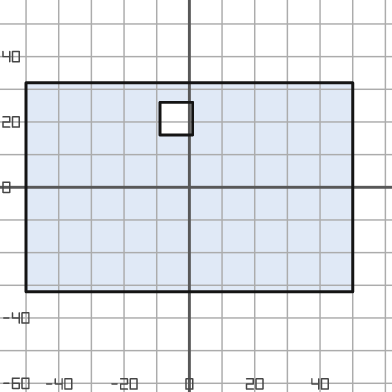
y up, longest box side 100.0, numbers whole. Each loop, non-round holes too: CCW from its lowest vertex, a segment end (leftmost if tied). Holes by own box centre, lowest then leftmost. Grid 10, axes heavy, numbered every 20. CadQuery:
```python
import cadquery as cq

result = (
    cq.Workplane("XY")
    .moveTo(-50.0, -32.0)
    .lineTo(50.0, -32.0)
    .lineTo(50.0, 32.0)
    .lineTo(-50.0, 32.0)
    .close()
    .moveTo(-9.0, 16.0)
    .lineTo(1.0, 16.0)
    .lineTo(1.0, 26.0)
    .lineTo(-9.0, 26.0)
    .close()
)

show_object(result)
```